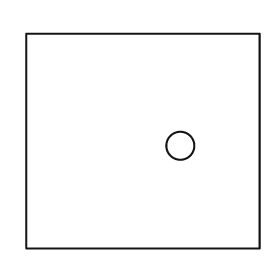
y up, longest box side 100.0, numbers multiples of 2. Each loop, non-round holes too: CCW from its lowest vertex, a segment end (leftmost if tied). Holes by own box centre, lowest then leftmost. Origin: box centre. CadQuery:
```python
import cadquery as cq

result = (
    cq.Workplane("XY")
    .moveTo(-50.0, -46.0)
    .lineTo(50.0, -46.0)
    .lineTo(50.0, 46.0)
    .lineTo(-50.0, 46.0)
    .close()
    .moveTo(16.0, -2.0)
    .circle(6.0)
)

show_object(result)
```